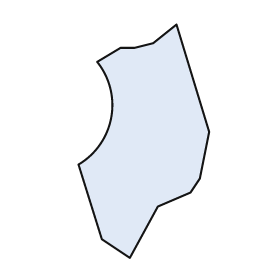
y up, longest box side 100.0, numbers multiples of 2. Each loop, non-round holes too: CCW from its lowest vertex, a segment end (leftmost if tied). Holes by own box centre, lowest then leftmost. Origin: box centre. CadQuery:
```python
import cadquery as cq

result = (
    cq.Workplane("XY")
    .moveTo(-6.0, -50.0)
    .lineTo(6.0, -28.0)
    .lineTo(20.0, -22.0)
    .lineTo(24.0, -16.0)
    .lineTo(28.0, 4.0)
    .lineTo(14.0, 50.0)
    .lineTo(4.0, 42.0)
    .lineTo(-4.0, 40.0)
    .lineTo(-10.0, 40.0)
    .lineTo(-20.0, 34.0)
    .threePointArc((-14.0, 10.0), (-28.0, -10.0))
    .lineTo(-18.0, -42.0)
    .close()
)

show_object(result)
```